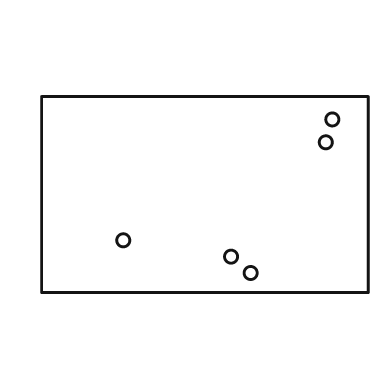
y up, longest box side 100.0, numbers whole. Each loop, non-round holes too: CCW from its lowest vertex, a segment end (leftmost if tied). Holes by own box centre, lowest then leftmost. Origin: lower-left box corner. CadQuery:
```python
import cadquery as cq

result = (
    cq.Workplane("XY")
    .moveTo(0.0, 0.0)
    .lineTo(100.0, 0.0)
    .lineTo(100.0, 60.0)
    .lineTo(0.0, 60.0)
    .close()
    .moveTo(64.0, 6.0)
    .circle(2.0)
    .moveTo(58.0, 11.0)
    .circle(2.0)
    .moveTo(25.0, 16.0)
    .circle(2.0)
    .moveTo(87.0, 46.0)
    .circle(2.0)
    .moveTo(89.0, 53.0)
    .circle(2.0)
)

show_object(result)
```